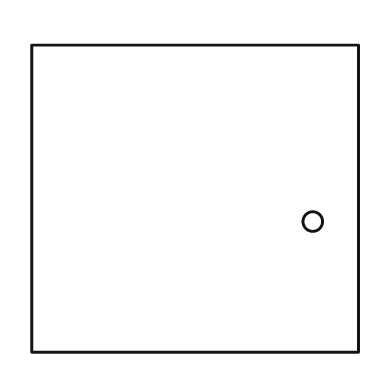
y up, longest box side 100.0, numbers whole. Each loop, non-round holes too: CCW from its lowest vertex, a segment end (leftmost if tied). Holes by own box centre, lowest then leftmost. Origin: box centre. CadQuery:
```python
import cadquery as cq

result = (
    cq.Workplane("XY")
    .moveTo(-50.0, -47.0)
    .lineTo(50.0, -47.0)
    .lineTo(50.0, 47.0)
    .lineTo(-50.0, 47.0)
    .close()
    .moveTo(36.0, -7.0)
    .circle(3.0)
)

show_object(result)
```